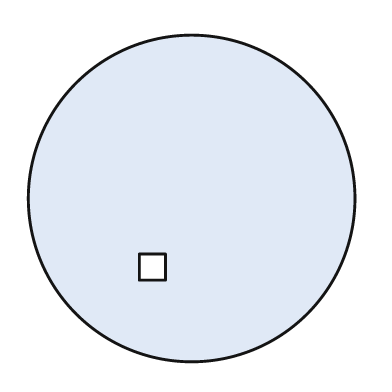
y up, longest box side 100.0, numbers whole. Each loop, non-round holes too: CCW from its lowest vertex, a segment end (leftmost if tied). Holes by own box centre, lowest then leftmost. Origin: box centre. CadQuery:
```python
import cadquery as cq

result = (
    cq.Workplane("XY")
    .moveTo(0.0, 0.0)
    .circle(50.0)
    .moveTo(-16.0, -25.0)
    .lineTo(-8.0, -25.0)
    .lineTo(-8.0, -17.0)
    .lineTo(-16.0, -17.0)
    .close()
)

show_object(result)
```